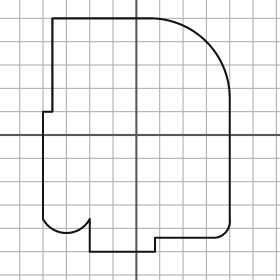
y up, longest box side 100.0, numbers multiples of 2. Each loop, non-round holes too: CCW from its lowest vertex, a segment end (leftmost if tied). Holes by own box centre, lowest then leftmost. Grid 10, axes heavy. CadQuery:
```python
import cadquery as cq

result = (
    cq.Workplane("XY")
    .moveTo(-20.0, -50.0)
    .lineTo(8.0, -50.0)
    .lineTo(8.0, -44.0)
    .lineTo(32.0, -44.0)
    .threePointArc((38.0, -42.0), (40.0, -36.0))
    .lineTo(40.0, 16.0)
    .threePointArc((30.0, 40.0), (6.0, 50.0))
    .lineTo(-36.0, 50.0)
    .lineTo(-36.0, 10.0)
    .lineTo(-40.0, 10.0)
    .lineTo(-40.0, -36.0)
    .threePointArc((-30.0, -42.0), (-20.0, -36.0))
    .close()
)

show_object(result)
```